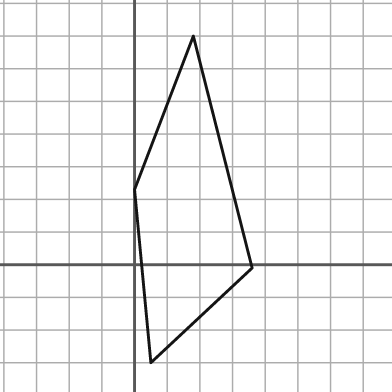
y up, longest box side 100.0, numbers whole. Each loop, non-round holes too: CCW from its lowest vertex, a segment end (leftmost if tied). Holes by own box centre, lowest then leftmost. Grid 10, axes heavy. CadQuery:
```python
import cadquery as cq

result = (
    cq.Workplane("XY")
    .moveTo(5.0, -30.0)
    .lineTo(36.0, -1.0)
    .lineTo(18.0, 70.0)
    .lineTo(0.0, 23.0)
    .close()
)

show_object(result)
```